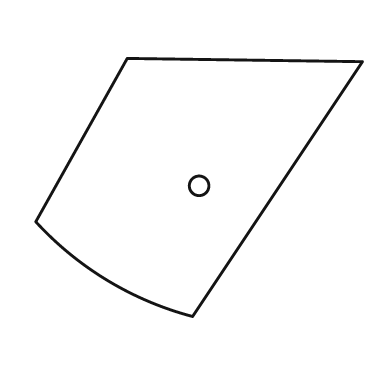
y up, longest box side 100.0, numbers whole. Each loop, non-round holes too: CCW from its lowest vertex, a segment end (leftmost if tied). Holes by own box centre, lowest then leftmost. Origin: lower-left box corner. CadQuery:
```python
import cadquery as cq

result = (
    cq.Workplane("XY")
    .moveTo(48.0, 0.0)
    .lineTo(100.0, 78.0)
    .lineTo(28.0, 79.0)
    .lineTo(0.0, 29.0)
    .threePointArc((22.0, 11.0), (48.0, 0.0))
    .close()
    .moveTo(50.0, 40.0)
    .circle(3.0)
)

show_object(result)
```